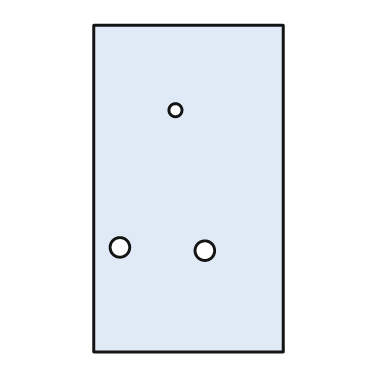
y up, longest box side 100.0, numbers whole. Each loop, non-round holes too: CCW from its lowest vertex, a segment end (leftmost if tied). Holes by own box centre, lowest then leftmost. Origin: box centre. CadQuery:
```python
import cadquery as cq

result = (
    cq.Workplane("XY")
    .moveTo(-29.0, -50.0)
    .lineTo(29.0, -50.0)
    .lineTo(29.0, 50.0)
    .lineTo(-29.0, 50.0)
    .close()
    .moveTo(5.0, -19.0)
    .circle(3.0)
    .moveTo(-21.0, -18.0)
    .circle(3.0)
    .moveTo(-4.0, 24.0)
    .circle(2.0)
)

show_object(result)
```